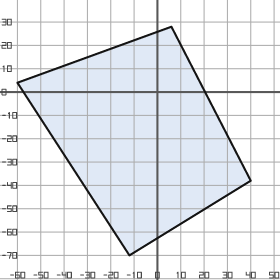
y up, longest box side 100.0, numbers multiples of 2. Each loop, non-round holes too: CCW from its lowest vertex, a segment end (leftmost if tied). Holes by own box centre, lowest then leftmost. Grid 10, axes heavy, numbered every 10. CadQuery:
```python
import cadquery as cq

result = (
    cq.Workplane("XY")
    .moveTo(-12.0, -70.0)
    .lineTo(40.0, -38.0)
    .lineTo(6.0, 28.0)
    .lineTo(-60.0, 4.0)
    .close()
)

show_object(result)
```